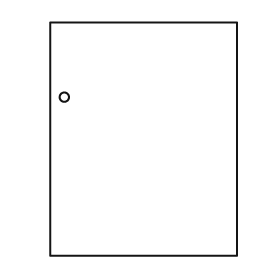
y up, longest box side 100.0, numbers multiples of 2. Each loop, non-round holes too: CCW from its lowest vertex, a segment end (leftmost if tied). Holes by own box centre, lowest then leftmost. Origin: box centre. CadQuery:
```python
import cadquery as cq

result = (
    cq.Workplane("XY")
    .moveTo(-40.0, -50.0)
    .lineTo(40.0, -50.0)
    .lineTo(40.0, 50.0)
    .lineTo(-40.0, 50.0)
    .close()
    .moveTo(-34.0, 18.0)
    .circle(2.0)
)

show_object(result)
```